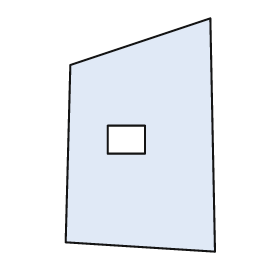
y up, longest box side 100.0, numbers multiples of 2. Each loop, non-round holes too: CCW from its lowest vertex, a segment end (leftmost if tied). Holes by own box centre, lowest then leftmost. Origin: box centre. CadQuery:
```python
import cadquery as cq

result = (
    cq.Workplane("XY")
    .moveTo(32.0, -50.0)
    .lineTo(30.0, 50.0)
    .lineTo(-30.0, 30.0)
    .lineTo(-32.0, -46.0)
    .close()
    .moveTo(-14.0, -8.0)
    .lineTo(2.0, -8.0)
    .lineTo(2.0, 4.0)
    .lineTo(-14.0, 4.0)
    .close()
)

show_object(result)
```